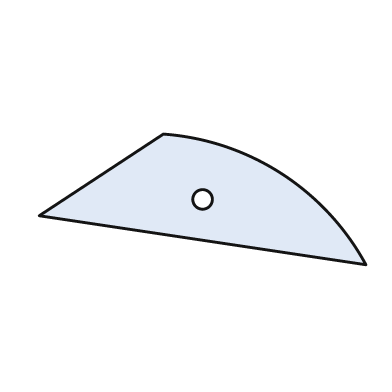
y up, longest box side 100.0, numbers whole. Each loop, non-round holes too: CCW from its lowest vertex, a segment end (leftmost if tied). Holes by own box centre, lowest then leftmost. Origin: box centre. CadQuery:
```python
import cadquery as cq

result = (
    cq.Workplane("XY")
    .moveTo(50.0, -20.0)
    .threePointArc((24.0, 8.0), (-12.0, 20.0))
    .lineTo(-50.0, -5.0)
    .close()
    .moveTo(0.0, 0.0)
    .circle(3.0)
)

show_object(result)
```